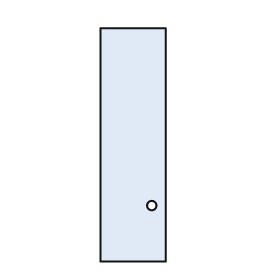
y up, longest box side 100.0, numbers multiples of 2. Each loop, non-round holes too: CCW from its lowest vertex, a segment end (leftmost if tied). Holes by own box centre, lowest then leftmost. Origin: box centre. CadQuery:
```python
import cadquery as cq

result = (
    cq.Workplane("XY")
    .moveTo(-14.0, -50.0)
    .lineTo(14.0, -50.0)
    .lineTo(14.0, 50.0)
    .lineTo(-14.0, 50.0)
    .close()
    .moveTo(8.0, -26.0)
    .circle(2.0)
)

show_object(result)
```